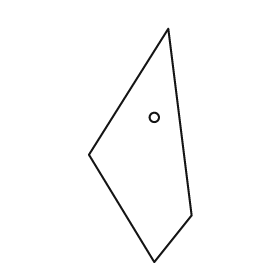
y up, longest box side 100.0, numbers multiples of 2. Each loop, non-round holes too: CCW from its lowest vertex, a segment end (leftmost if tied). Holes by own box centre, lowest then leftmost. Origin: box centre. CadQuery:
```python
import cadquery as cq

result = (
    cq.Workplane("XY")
    .moveTo(6.0, -50.0)
    .lineTo(22.0, -30.0)
    .lineTo(12.0, 50.0)
    .lineTo(-22.0, -4.0)
    .close()
    .moveTo(6.0, 12.0)
    .circle(2.0)
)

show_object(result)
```